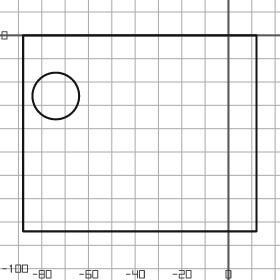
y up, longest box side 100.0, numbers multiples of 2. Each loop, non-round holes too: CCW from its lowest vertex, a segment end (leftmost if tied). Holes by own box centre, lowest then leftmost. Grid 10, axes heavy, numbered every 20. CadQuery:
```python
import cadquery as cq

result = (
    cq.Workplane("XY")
    .moveTo(-88.0, -84.0)
    .lineTo(12.0, -84.0)
    .lineTo(12.0, 0.0)
    .lineTo(-88.0, 0.0)
    .close()
    .moveTo(-74.0, -26.0)
    .circle(10.0)
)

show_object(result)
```